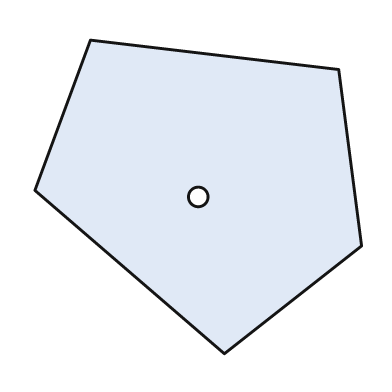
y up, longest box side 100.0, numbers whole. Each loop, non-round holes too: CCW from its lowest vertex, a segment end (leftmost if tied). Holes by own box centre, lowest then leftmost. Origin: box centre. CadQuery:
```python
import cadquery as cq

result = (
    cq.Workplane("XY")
    .moveTo(8.0, -48.0)
    .lineTo(50.0, -15.0)
    .lineTo(43.0, 39.0)
    .lineTo(-33.0, 48.0)
    .lineTo(-50.0, 2.0)
    .close()
    .moveTo(0.0, 0.0)
    .circle(3.0)
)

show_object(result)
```